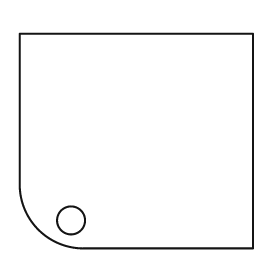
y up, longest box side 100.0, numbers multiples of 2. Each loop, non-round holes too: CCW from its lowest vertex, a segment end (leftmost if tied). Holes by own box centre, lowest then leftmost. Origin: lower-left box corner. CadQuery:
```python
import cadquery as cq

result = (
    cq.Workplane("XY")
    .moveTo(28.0, 0.0)
    .lineTo(100.0, 0.0)
    .lineTo(100.0, 92.0)
    .lineTo(0.0, 92.0)
    .lineTo(0.0, 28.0)
    .threePointArc((8.0, 8.0), (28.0, 0.0))
    .close()
    .moveTo(22.0, 12.0)
    .circle(6.0)
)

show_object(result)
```